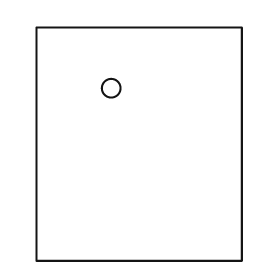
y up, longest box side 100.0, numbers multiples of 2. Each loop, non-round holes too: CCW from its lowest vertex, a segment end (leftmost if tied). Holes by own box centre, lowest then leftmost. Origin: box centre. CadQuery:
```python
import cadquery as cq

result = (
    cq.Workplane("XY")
    .moveTo(-44.0, -50.0)
    .lineTo(44.0, -50.0)
    .lineTo(44.0, 50.0)
    .lineTo(-44.0, 50.0)
    .close()
    .moveTo(-12.0, 24.0)
    .circle(4.0)
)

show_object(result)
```